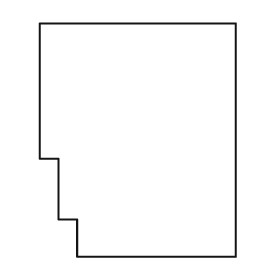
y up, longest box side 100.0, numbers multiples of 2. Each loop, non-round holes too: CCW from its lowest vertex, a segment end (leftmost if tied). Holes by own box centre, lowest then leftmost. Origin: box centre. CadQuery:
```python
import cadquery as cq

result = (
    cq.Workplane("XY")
    .moveTo(-26.0, -50.0)
    .lineTo(42.0, -50.0)
    .lineTo(42.0, 50.0)
    .lineTo(-42.0, 50.0)
    .lineTo(-42.0, -8.0)
    .lineTo(-34.0, -8.0)
    .lineTo(-34.0, -34.0)
    .lineTo(-26.0, -34.0)
    .close()
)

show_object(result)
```